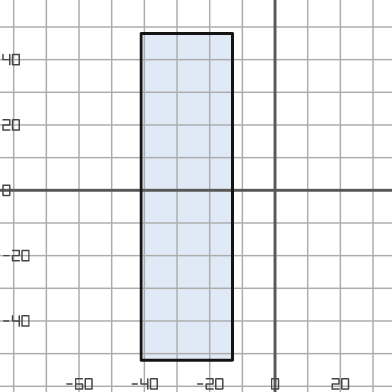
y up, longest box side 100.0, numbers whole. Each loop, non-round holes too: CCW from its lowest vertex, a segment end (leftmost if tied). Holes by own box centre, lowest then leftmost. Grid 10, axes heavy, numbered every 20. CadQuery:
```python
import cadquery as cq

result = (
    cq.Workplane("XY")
    .moveTo(-41.0, -52.0)
    .lineTo(-13.0, -52.0)
    .lineTo(-13.0, 48.0)
    .lineTo(-41.0, 48.0)
    .close()
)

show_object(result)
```